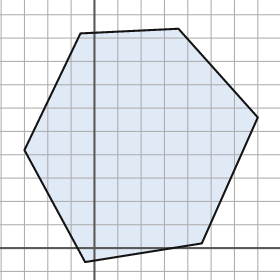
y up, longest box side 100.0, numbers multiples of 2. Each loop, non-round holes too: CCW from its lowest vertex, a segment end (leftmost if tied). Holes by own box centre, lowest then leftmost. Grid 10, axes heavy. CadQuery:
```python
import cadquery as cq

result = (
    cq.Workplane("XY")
    .moveTo(-4.0, -6.0)
    .lineTo(46.0, 2.0)
    .lineTo(70.0, 56.0)
    .lineTo(36.0, 94.0)
    .lineTo(-6.0, 92.0)
    .lineTo(-30.0, 42.0)
    .close()
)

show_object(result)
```